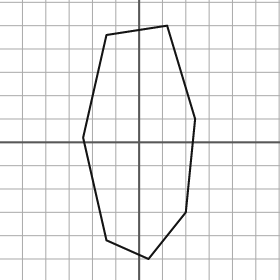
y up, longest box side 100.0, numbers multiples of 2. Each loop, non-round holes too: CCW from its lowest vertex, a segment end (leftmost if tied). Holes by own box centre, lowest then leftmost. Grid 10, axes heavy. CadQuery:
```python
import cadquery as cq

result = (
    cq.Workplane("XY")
    .moveTo(4.0, -50.0)
    .lineTo(20.0, -30.0)
    .lineTo(24.0, 10.0)
    .lineTo(12.0, 50.0)
    .lineTo(-14.0, 46.0)
    .lineTo(-24.0, 2.0)
    .lineTo(-14.0, -42.0)
    .close()
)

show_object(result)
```